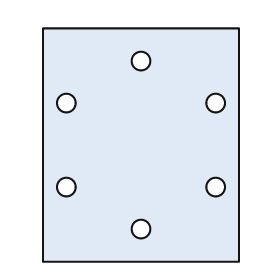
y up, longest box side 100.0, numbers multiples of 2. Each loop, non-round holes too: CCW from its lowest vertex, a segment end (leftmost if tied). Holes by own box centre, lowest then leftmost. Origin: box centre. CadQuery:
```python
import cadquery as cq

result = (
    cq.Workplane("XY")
    .moveTo(-42.0, -50.0)
    .lineTo(42.0, -50.0)
    .lineTo(42.0, 50.0)
    .lineTo(-42.0, 50.0)
    .close()
    .moveTo(0.0, -36.0)
    .circle(4.0)
    .moveTo(-32.0, -18.0)
    .circle(4.0)
    .moveTo(32.0, -18.0)
    .circle(4.0)
    .moveTo(-32.0, 18.0)
    .circle(4.0)
    .moveTo(32.0, 18.0)
    .circle(4.0)
    .moveTo(0.0, 36.0)
    .circle(4.0)
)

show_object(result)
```